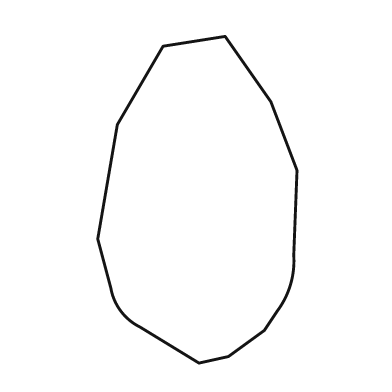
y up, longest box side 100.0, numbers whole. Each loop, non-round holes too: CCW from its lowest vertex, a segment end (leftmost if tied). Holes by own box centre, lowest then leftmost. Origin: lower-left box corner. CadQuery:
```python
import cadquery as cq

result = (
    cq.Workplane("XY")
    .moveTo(31.0, 0.0)
    .lineTo(40.0, 2.0)
    .lineTo(51.0, 10.0)
    .lineTo(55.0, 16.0)
    .threePointArc((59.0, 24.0), (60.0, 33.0))
    .lineTo(61.0, 59.0)
    .lineTo(53.0, 80.0)
    .lineTo(39.0, 100.0)
    .lineTo(20.0, 97.0)
    .lineTo(6.0, 73.0)
    .lineTo(0.0, 38.0)
    .lineTo(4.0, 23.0)
    .threePointArc((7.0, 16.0), (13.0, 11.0))
    .close()
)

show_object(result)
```